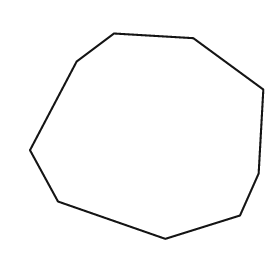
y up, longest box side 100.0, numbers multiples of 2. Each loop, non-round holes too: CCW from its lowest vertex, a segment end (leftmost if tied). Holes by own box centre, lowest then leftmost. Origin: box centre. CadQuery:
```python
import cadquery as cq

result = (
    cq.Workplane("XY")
    .moveTo(8.0, -44.0)
    .lineTo(40.0, -34.0)
    .lineTo(48.0, -16.0)
    .lineTo(50.0, 20.0)
    .lineTo(20.0, 42.0)
    .lineTo(-14.0, 44.0)
    .lineTo(-30.0, 32.0)
    .lineTo(-50.0, -6.0)
    .lineTo(-38.0, -28.0)
    .close()
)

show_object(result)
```